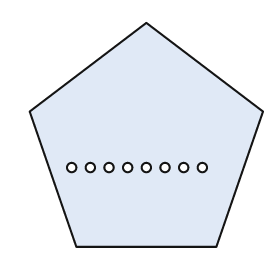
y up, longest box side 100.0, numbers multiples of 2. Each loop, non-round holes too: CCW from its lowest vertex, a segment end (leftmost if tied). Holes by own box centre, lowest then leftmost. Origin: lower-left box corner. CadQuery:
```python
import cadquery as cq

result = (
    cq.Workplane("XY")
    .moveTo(20.0, 0.0)
    .lineTo(80.0, 0.0)
    .lineTo(100.0, 58.0)
    .lineTo(50.0, 96.0)
    .lineTo(0.0, 58.0)
    .close()
    .moveTo(18.0, 34.0)
    .circle(2.0)
    .moveTo(26.0, 34.0)
    .circle(2.0)
    .moveTo(34.0, 34.0)
    .circle(2.0)
    .moveTo(42.0, 34.0)
    .circle(2.0)
    .moveTo(50.0, 34.0)
    .circle(2.0)
    .moveTo(58.0, 34.0)
    .circle(2.0)
    .moveTo(66.0, 34.0)
    .circle(2.0)
    .moveTo(74.0, 34.0)
    .circle(2.0)
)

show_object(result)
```